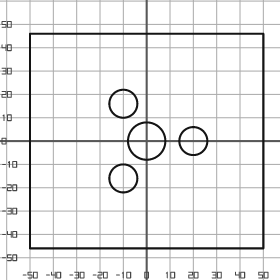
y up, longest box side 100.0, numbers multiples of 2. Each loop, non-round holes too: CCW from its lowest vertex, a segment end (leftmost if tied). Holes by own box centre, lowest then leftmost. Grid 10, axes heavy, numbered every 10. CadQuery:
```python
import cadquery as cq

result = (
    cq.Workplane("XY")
    .moveTo(-50.0, -46.0)
    .lineTo(50.0, -46.0)
    .lineTo(50.0, 46.0)
    .lineTo(-50.0, 46.0)
    .close()
    .moveTo(-10.0, -16.0)
    .circle(6.0)
    .moveTo(0.0, 0.0)
    .circle(8.0)
    .moveTo(20.0, 0.0)
    .circle(6.0)
    .moveTo(-10.0, 16.0)
    .circle(6.0)
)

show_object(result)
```